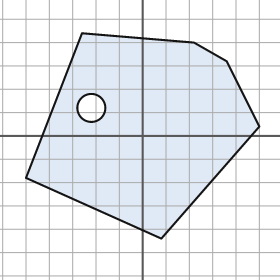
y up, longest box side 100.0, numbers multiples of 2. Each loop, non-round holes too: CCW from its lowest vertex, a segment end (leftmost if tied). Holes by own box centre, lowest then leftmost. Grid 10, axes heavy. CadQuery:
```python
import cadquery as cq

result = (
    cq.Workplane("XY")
    .moveTo(8.0, -44.0)
    .lineTo(50.0, 4.0)
    .lineTo(36.0, 32.0)
    .lineTo(22.0, 40.0)
    .lineTo(-26.0, 44.0)
    .lineTo(-50.0, -18.0)
    .close()
    .moveTo(-22.0, 12.0)
    .circle(6.0)
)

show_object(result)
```